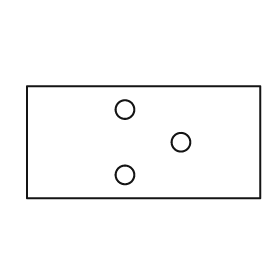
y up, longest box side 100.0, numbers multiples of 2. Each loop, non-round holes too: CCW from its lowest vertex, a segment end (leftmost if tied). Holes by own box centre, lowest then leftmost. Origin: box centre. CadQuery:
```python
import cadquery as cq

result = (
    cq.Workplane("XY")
    .moveTo(-50.0, -24.0)
    .lineTo(50.0, -24.0)
    .lineTo(50.0, 24.0)
    .lineTo(-50.0, 24.0)
    .close()
    .moveTo(-8.0, -14.0)
    .circle(4.0)
    .moveTo(16.0, 0.0)
    .circle(4.0)
    .moveTo(-8.0, 14.0)
    .circle(4.0)
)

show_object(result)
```